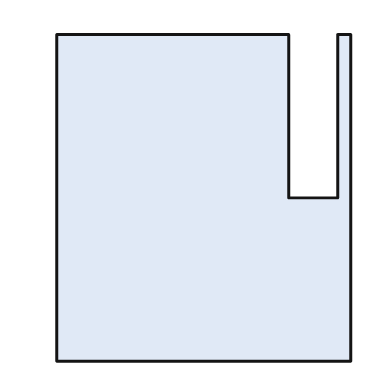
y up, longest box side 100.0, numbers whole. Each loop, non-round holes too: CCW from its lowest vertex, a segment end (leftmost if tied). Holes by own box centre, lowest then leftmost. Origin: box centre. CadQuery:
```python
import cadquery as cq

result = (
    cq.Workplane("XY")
    .moveTo(-45.0, -50.0)
    .lineTo(45.0, -50.0)
    .lineTo(45.0, 50.0)
    .lineTo(41.0, 50.0)
    .lineTo(41.0, 0.0)
    .lineTo(26.0, 0.0)
    .lineTo(26.0, 50.0)
    .lineTo(-45.0, 50.0)
    .close()
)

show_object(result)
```